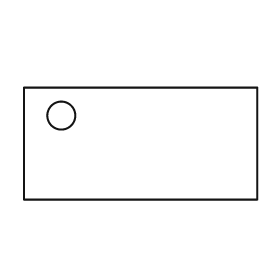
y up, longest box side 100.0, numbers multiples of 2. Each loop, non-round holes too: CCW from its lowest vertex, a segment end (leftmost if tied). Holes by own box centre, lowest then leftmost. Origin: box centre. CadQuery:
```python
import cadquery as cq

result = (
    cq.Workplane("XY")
    .moveTo(-50.0, -24.0)
    .lineTo(50.0, -24.0)
    .lineTo(50.0, 24.0)
    .lineTo(-50.0, 24.0)
    .close()
    .moveTo(-34.0, 12.0)
    .circle(6.0)
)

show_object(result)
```